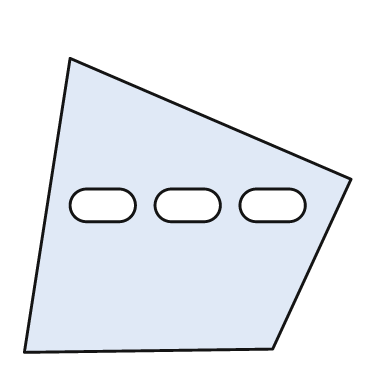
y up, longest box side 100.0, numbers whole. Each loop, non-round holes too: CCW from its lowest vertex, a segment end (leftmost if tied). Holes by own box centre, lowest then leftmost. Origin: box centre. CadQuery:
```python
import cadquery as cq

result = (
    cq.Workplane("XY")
    .moveTo(-50.0, -45.0)
    .lineTo(26.0, -44.0)
    .lineTo(50.0, 8.0)
    .lineTo(-36.0, 45.0)
    .close()
    .moveTo(-31.0, -5.0)
    .lineTo(-21.0, -5.0)
    .threePointArc((-16.0, 0.0), (-21.0, 5.0))
    .lineTo(-31.0, 5.0)
    .threePointArc((-36.0, 0.0), (-31.0, -5.0))
    .close()
    .moveTo(-5.0, -5.0)
    .lineTo(5.0, -5.0)
    .threePointArc((10.0, 0.0), (5.0, 5.0))
    .lineTo(-5.0, 5.0)
    .threePointArc((-10.0, 0.0), (-5.0, -5.0))
    .close()
    .moveTo(21.0, -5.0)
    .lineTo(31.0, -5.0)
    .threePointArc((36.0, 0.0), (31.0, 5.0))
    .lineTo(21.0, 5.0)
    .threePointArc((16.0, 0.0), (21.0, -5.0))
    .close()
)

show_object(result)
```